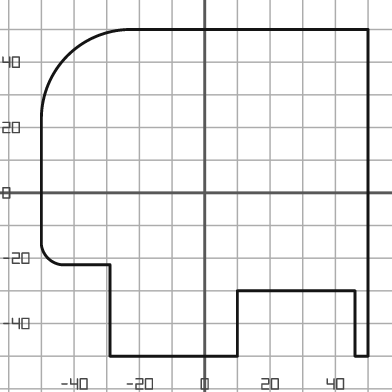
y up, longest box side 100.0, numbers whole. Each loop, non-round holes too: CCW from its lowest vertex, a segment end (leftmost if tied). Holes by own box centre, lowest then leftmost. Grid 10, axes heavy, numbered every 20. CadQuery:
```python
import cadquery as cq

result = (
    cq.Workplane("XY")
    .moveTo(-29.0, -50.0)
    .lineTo(10.0, -50.0)
    .lineTo(10.0, -30.0)
    .lineTo(46.0, -30.0)
    .lineTo(46.0, -50.0)
    .lineTo(50.0, -50.0)
    .lineTo(50.0, 50.0)
    .lineTo(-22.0, 50.0)
    .threePointArc((-42.0, 42.0), (-50.0, 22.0))
    .lineTo(-50.0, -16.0)
    .threePointArc((-48.0, -20.0), (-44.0, -22.0))
    .lineTo(-29.0, -22.0)
    .close()
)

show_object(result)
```